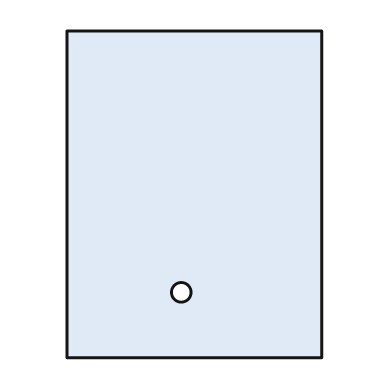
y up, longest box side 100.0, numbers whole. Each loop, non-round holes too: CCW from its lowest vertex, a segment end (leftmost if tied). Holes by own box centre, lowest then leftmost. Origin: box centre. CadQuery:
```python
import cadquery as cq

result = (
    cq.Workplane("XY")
    .moveTo(-39.0, -50.0)
    .lineTo(39.0, -50.0)
    .lineTo(39.0, 50.0)
    .lineTo(-39.0, 50.0)
    .close()
    .moveTo(-4.0, -30.0)
    .circle(3.0)
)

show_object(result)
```